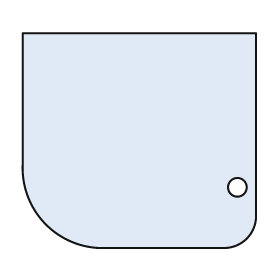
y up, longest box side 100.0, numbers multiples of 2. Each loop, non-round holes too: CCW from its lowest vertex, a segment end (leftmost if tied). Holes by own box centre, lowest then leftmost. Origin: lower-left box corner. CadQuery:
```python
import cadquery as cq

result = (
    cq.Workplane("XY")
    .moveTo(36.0, 0.0)
    .lineTo(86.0, 0.0)
    .threePointArc((96.0, 4.0), (100.0, 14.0))
    .lineTo(100.0, 92.0)
    .lineTo(0.0, 92.0)
    .lineTo(0.0, 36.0)
    .threePointArc((10.0, 10.0), (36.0, 0.0))
    .close()
    .moveTo(92.0, 26.0)
    .circle(4.0)
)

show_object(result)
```